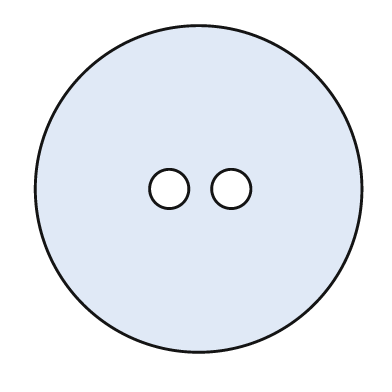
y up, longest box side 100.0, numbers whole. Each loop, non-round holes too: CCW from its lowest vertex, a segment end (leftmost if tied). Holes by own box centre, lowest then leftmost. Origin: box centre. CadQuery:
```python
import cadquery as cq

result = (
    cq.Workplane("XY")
    .moveTo(0.0, 0.0)
    .circle(50.0)
    .moveTo(-9.0, 0.0)
    .circle(6.0)
    .moveTo(10.0, 0.0)
    .circle(6.0)
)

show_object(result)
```